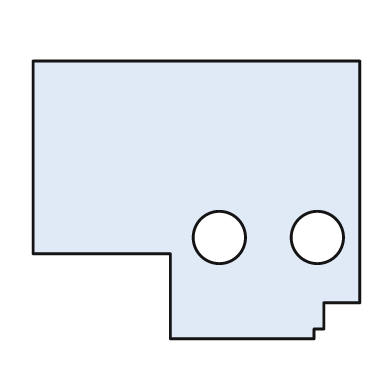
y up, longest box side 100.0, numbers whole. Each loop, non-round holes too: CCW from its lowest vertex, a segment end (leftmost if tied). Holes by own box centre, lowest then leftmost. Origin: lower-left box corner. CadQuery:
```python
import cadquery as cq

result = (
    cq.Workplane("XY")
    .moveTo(42.0, 0.0)
    .lineTo(86.0, 0.0)
    .lineTo(86.0, 3.0)
    .lineTo(89.0, 3.0)
    .lineTo(89.0, 11.0)
    .lineTo(100.0, 11.0)
    .lineTo(100.0, 85.0)
    .lineTo(0.0, 85.0)
    .lineTo(0.0, 26.0)
    .lineTo(42.0, 26.0)
    .close()
    .moveTo(57.0, 31.0)
    .circle(8.0)
    .moveTo(87.0, 31.0)
    .circle(8.0)
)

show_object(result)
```